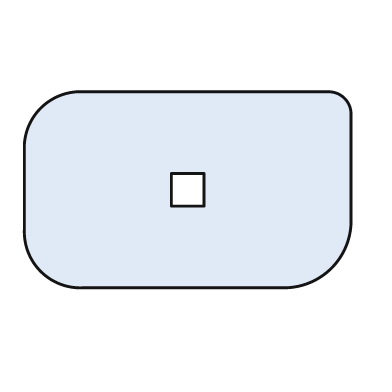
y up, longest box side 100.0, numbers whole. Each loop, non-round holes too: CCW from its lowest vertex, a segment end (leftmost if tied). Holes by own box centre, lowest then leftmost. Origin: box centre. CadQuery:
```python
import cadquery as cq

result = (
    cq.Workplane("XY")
    .moveTo(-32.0, -30.0)
    .lineTo(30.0, -30.0)
    .threePointArc((44.0, -24.0), (50.0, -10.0))
    .lineTo(50.0, 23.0)
    .threePointArc((48.0, 28.0), (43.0, 30.0))
    .lineTo(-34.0, 30.0)
    .threePointArc((-45.0, 25.0), (-50.0, 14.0))
    .lineTo(-50.0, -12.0)
    .threePointArc((-45.0, -25.0), (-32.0, -30.0))
    .close()
    .moveTo(-5.0, -5.0)
    .lineTo(5.0, -5.0)
    .lineTo(5.0, 5.0)
    .lineTo(-5.0, 5.0)
    .close()
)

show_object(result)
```